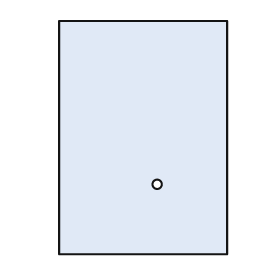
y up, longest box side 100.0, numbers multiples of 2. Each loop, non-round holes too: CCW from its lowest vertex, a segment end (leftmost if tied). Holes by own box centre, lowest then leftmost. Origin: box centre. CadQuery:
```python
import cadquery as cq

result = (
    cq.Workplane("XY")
    .moveTo(-36.0, -50.0)
    .lineTo(36.0, -50.0)
    .lineTo(36.0, 50.0)
    .lineTo(-36.0, 50.0)
    .close()
    .moveTo(6.0, -20.0)
    .circle(2.0)
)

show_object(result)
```